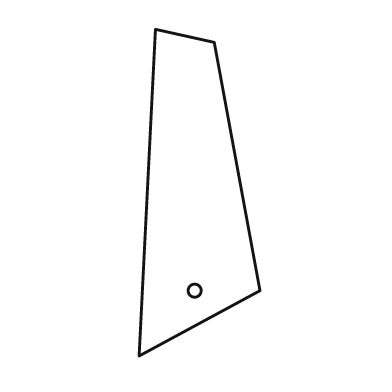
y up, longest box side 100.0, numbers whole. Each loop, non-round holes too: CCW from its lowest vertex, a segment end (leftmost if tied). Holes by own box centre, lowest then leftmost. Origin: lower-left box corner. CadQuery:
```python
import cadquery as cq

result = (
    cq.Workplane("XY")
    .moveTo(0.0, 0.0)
    .lineTo(37.0, 20.0)
    .lineTo(23.0, 96.0)
    .lineTo(5.0, 100.0)
    .close()
    .moveTo(17.0, 20.0)
    .circle(2.0)
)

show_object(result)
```